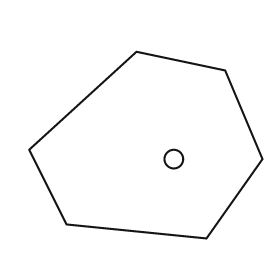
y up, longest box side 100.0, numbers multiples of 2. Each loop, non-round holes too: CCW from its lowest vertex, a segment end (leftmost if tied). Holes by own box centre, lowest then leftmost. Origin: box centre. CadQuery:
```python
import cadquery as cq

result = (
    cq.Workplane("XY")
    .moveTo(26.0, -40.0)
    .lineTo(50.0, -6.0)
    .lineTo(34.0, 32.0)
    .lineTo(-4.0, 40.0)
    .lineTo(-50.0, -2.0)
    .lineTo(-34.0, -34.0)
    .close()
    .moveTo(12.0, -6.0)
    .circle(4.0)
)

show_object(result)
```